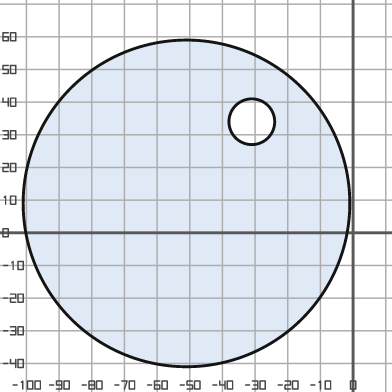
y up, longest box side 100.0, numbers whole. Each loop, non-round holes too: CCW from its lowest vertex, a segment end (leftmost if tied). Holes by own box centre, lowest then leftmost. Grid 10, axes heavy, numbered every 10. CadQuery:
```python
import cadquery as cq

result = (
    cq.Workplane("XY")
    .moveTo(-51.0, 9.0)
    .circle(50.0)
    .moveTo(-31.0, 34.0)
    .circle(7.0)
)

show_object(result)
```